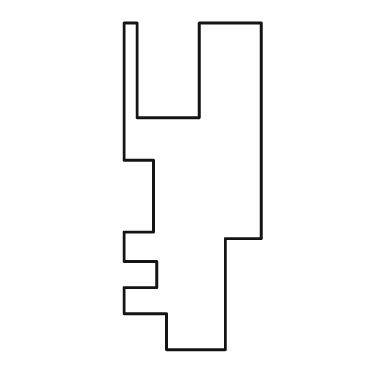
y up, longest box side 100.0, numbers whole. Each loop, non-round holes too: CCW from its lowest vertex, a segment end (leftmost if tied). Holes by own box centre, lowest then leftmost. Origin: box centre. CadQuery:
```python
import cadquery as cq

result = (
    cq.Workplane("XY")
    .moveTo(-8.0, -50.0)
    .lineTo(10.0, -50.0)
    .lineTo(10.0, -16.0)
    .lineTo(21.0, -16.0)
    .lineTo(21.0, 50.0)
    .lineTo(2.0, 50.0)
    .lineTo(2.0, 21.0)
    .lineTo(-17.0, 21.0)
    .lineTo(-17.0, 50.0)
    .lineTo(-21.0, 50.0)
    .lineTo(-21.0, 8.0)
    .lineTo(-12.0, 8.0)
    .lineTo(-12.0, -14.0)
    .lineTo(-21.0, -14.0)
    .lineTo(-21.0, -23.0)
    .lineTo(-11.0, -23.0)
    .lineTo(-11.0, -31.0)
    .lineTo(-21.0, -31.0)
    .lineTo(-21.0, -39.0)
    .lineTo(-8.0, -39.0)
    .close()
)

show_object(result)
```